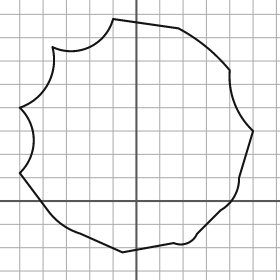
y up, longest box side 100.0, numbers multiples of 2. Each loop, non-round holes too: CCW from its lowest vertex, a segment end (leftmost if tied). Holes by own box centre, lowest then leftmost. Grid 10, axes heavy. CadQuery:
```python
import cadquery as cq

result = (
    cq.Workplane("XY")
    .moveTo(-6.0, -22.0)
    .lineTo(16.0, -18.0)
    .threePointArc((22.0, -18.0), (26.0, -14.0))
    .lineTo(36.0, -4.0)
    .threePointArc((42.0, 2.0), (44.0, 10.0))
    .lineTo(50.0, 30.0)
    .threePointArc((42.0, 42.0), (40.0, 56.0))
    .threePointArc((30.0, 66.0), (18.0, 74.0))
    .lineTo(-10.0, 78.0)
    .threePointArc((-20.0, 66.0), (-36.0, 66.0))
    .threePointArc((-38.0, 50.0), (-50.0, 40.0))
    .threePointArc((-44.0, 26.0), (-50.0, 12.0))
    .lineTo(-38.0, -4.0)
    .threePointArc((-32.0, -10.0), (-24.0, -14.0))
    .close()
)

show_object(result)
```